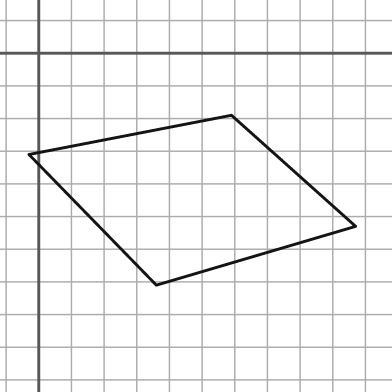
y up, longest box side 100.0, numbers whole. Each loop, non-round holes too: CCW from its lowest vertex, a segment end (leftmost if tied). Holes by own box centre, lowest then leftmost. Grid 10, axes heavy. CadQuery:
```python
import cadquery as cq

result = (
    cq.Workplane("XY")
    .moveTo(36.0, -71.0)
    .lineTo(97.0, -53.0)
    .lineTo(59.0, -19.0)
    .lineTo(-3.0, -31.0)
    .close()
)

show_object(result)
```